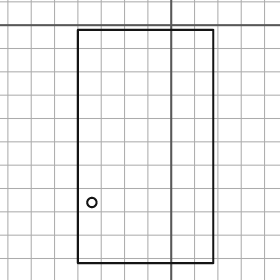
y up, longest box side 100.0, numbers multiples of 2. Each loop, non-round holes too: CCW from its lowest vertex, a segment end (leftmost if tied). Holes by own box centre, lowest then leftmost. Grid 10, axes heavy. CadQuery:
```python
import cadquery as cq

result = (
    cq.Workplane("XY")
    .moveTo(-40.0, -102.0)
    .lineTo(18.0, -102.0)
    .lineTo(18.0, -2.0)
    .lineTo(-40.0, -2.0)
    .close()
    .moveTo(-34.0, -76.0)
    .circle(2.0)
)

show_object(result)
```